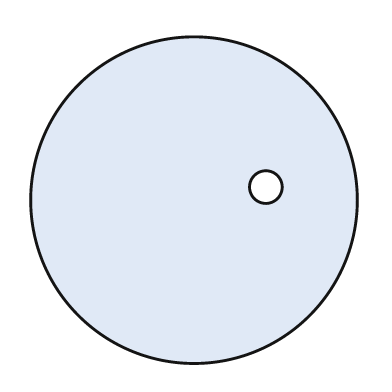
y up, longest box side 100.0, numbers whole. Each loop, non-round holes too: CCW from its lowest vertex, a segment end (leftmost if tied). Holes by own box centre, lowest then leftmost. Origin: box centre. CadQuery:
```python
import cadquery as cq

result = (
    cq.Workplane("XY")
    .moveTo(0.0, 0.0)
    .circle(50.0)
    .moveTo(22.0, 4.0)
    .circle(5.0)
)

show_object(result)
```